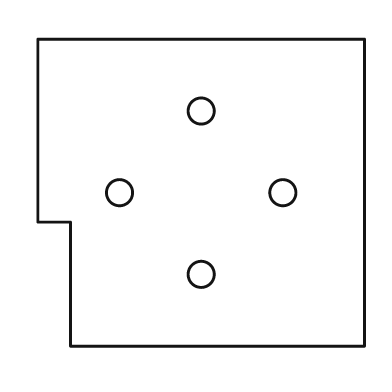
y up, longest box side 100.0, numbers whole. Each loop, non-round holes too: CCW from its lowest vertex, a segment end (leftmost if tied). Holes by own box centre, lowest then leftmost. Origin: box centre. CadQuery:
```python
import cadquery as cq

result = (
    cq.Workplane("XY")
    .moveTo(-40.0, -47.0)
    .lineTo(50.0, -47.0)
    .lineTo(50.0, 47.0)
    .lineTo(-50.0, 47.0)
    .lineTo(-50.0, -9.0)
    .lineTo(-40.0, -9.0)
    .close()
    .moveTo(0.0, -25.0)
    .circle(4.0)
    .moveTo(-25.0, 0.0)
    .circle(4.0)
    .moveTo(25.0, 0.0)
    .circle(4.0)
    .moveTo(0.0, 25.0)
    .circle(4.0)
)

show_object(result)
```